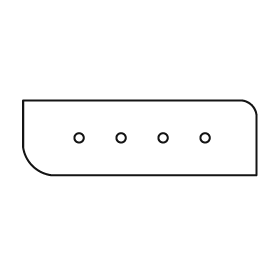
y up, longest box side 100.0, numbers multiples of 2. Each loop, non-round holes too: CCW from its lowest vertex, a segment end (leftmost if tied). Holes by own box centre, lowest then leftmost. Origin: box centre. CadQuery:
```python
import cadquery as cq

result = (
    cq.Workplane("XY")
    .moveTo(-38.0, -16.0)
    .lineTo(50.0, -16.0)
    .lineTo(50.0, 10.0)
    .threePointArc((48.0, 14.0), (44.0, 16.0))
    .lineTo(-50.0, 16.0)
    .lineTo(-50.0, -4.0)
    .threePointArc((-46.0, -12.0), (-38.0, -16.0))
    .close()
    .moveTo(-26.0, 0.0)
    .circle(2.0)
    .moveTo(-8.0, 0.0)
    .circle(2.0)
    .moveTo(10.0, 0.0)
    .circle(2.0)
    .moveTo(28.0, 0.0)
    .circle(2.0)
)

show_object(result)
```